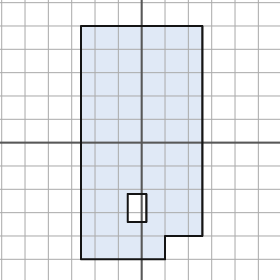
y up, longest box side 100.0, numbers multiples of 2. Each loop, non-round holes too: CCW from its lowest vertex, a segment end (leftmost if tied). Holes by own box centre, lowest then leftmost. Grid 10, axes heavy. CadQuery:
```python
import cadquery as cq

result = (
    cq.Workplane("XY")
    .moveTo(-26.0, -50.0)
    .lineTo(10.0, -50.0)
    .lineTo(10.0, -40.0)
    .lineTo(26.0, -40.0)
    .lineTo(26.0, 50.0)
    .lineTo(-26.0, 50.0)
    .close()
    .moveTo(-6.0, -34.0)
    .lineTo(2.0, -34.0)
    .lineTo(2.0, -22.0)
    .lineTo(-6.0, -22.0)
    .close()
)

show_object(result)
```